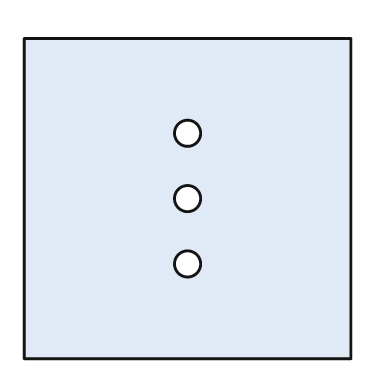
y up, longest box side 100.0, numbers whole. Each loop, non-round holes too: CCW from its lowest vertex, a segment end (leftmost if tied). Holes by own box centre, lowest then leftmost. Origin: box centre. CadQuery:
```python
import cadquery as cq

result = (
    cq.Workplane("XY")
    .moveTo(-50.0, -49.0)
    .lineTo(50.0, -49.0)
    .lineTo(50.0, 49.0)
    .lineTo(-50.0, 49.0)
    .close()
    .moveTo(0.0, -20.0)
    .circle(4.0)
    .moveTo(0.0, 0.0)
    .circle(4.0)
    .moveTo(0.0, 20.0)
    .circle(4.0)
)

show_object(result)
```